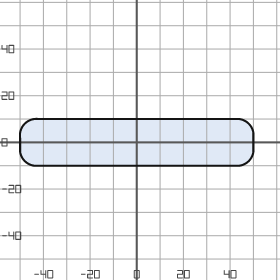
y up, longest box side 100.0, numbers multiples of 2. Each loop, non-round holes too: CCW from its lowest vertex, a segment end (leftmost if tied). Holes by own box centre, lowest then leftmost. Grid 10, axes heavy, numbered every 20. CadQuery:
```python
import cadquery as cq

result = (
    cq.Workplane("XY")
    .moveTo(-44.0, -10.0)
    .lineTo(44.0, -10.0)
    .threePointArc((48.0, -8.0), (50.0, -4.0))
    .lineTo(50.0, 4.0)
    .threePointArc((48.0, 8.0), (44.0, 10.0))
    .lineTo(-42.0, 10.0)
    .threePointArc((-48.0, 8.0), (-50.0, 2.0))
    .lineTo(-50.0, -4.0)
    .threePointArc((-48.0, -8.0), (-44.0, -10.0))
    .close()
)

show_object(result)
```